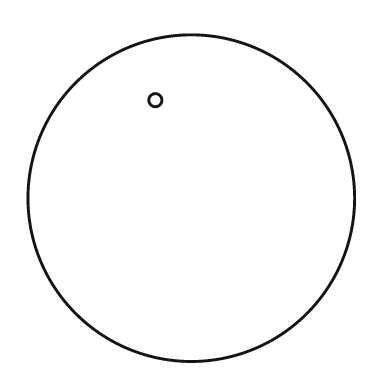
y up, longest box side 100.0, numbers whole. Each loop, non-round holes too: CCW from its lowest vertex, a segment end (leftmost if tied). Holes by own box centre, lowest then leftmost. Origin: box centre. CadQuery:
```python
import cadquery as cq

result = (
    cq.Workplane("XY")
    .moveTo(0.0, 0.0)
    .circle(50.0)
    .moveTo(-11.0, 30.0)
    .circle(2.0)
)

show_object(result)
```